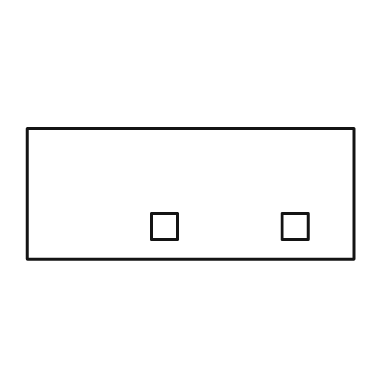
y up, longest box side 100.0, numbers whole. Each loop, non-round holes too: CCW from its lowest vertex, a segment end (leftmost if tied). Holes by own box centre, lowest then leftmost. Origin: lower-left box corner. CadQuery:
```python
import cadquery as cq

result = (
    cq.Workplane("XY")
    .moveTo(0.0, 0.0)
    .lineTo(100.0, 0.0)
    .lineTo(100.0, 40.0)
    .lineTo(0.0, 40.0)
    .close()
    .moveTo(38.0, 6.0)
    .lineTo(46.0, 6.0)
    .lineTo(46.0, 14.0)
    .lineTo(38.0, 14.0)
    .close()
    .moveTo(78.0, 6.0)
    .lineTo(86.0, 6.0)
    .lineTo(86.0, 14.0)
    .lineTo(78.0, 14.0)
    .close()
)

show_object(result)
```